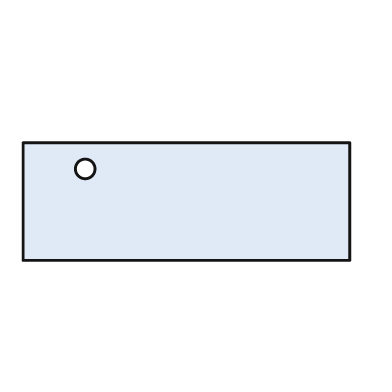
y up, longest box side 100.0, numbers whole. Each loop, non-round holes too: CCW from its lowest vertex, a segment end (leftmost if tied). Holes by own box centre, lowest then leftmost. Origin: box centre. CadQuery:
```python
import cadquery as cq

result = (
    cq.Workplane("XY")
    .moveTo(-50.0, -18.0)
    .lineTo(50.0, -18.0)
    .lineTo(50.0, 18.0)
    .lineTo(-50.0, 18.0)
    .close()
    .moveTo(-31.0, 10.0)
    .circle(3.0)
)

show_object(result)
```